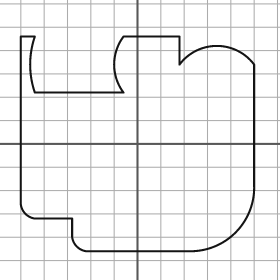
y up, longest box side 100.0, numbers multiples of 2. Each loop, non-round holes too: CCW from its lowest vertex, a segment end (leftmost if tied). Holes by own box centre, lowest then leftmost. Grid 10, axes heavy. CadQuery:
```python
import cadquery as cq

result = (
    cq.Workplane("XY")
    .moveTo(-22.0, -46.0)
    .lineTo(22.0, -46.0)
    .threePointArc((42.0, -38.0), (50.0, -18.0))
    .lineTo(50.0, 34.0)
    .threePointArc((34.0, 42.0), (18.0, 34.0))
    .lineTo(18.0, 46.0)
    .lineTo(-6.0, 46.0)
    .threePointArc((-10.0, 34.0), (-6.0, 22.0))
    .lineTo(-44.0, 22.0)
    .threePointArc((-46.0, 34.0), (-44.0, 46.0))
    .lineTo(-50.0, 46.0)
    .lineTo(-50.0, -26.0)
    .threePointArc((-48.0, -30.0), (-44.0, -32.0))
    .lineTo(-28.0, -32.0)
    .lineTo(-28.0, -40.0)
    .threePointArc((-26.0, -44.0), (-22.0, -46.0))
    .close()
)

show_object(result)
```